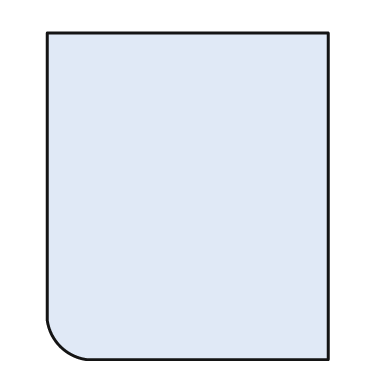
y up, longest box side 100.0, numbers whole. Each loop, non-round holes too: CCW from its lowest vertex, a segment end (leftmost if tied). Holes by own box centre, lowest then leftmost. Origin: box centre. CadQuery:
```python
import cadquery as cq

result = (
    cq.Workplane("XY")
    .moveTo(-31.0, -50.0)
    .lineTo(43.0, -50.0)
    .lineTo(43.0, 50.0)
    .lineTo(-43.0, 50.0)
    .lineTo(-43.0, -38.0)
    .threePointArc((-39.0, -46.0), (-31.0, -50.0))
    .close()
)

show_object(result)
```